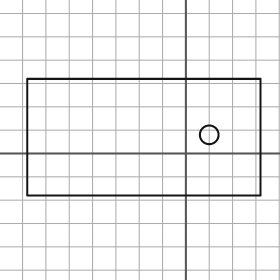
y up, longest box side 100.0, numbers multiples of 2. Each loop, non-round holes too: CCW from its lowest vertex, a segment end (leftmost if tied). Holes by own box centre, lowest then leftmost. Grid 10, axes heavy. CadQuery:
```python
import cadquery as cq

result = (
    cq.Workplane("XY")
    .moveTo(-68.0, -18.0)
    .lineTo(32.0, -18.0)
    .lineTo(32.0, 32.0)
    .lineTo(-68.0, 32.0)
    .close()
    .moveTo(10.0, 8.0)
    .circle(4.0)
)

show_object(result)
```